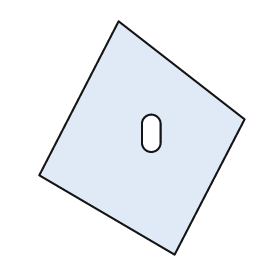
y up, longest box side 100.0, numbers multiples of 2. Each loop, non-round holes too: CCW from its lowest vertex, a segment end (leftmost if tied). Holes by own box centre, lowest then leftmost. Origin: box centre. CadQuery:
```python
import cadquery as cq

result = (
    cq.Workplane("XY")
    .moveTo(14.0, -50.0)
    .lineTo(44.0, 8.0)
    .lineTo(-10.0, 50.0)
    .lineTo(-44.0, -16.0)
    .close()
    .moveTo(0.0, -2.0)
    .threePointArc((4.0, -6.0), (8.0, -2.0))
    .lineTo(8.0, 6.0)
    .threePointArc((4.0, 10.0), (0.0, 6.0))
    .close()
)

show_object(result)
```